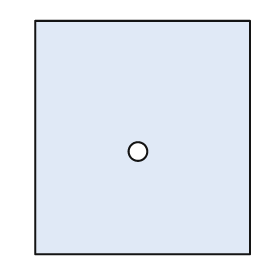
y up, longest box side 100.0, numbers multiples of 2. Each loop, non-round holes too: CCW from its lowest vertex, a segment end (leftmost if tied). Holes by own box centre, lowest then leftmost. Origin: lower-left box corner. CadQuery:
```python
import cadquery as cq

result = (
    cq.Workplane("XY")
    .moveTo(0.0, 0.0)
    .lineTo(92.0, 0.0)
    .lineTo(92.0, 100.0)
    .lineTo(0.0, 100.0)
    .close()
    .moveTo(44.0, 44.0)
    .circle(4.0)
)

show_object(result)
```